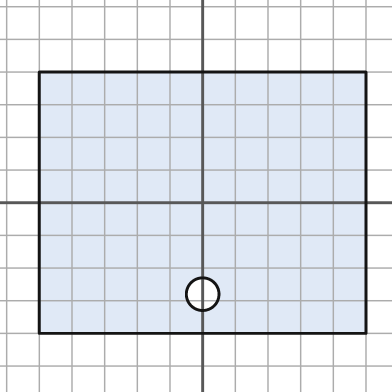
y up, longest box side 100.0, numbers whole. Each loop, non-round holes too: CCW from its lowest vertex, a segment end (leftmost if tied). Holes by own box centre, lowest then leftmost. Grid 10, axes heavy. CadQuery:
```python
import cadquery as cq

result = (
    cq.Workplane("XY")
    .moveTo(-50.0, -40.0)
    .lineTo(50.0, -40.0)
    .lineTo(50.0, 40.0)
    .lineTo(-50.0, 40.0)
    .close()
    .moveTo(0.0, -28.0)
    .circle(5.0)
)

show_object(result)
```